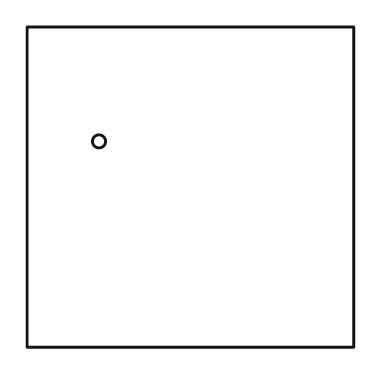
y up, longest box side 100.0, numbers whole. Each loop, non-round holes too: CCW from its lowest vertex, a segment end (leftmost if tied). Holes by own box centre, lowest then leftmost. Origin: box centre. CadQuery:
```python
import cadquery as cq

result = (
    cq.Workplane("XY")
    .moveTo(-50.0, -49.0)
    .lineTo(50.0, -49.0)
    .lineTo(50.0, 49.0)
    .lineTo(-50.0, 49.0)
    .close()
    .moveTo(-28.0, 14.0)
    .circle(2.0)
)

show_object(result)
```